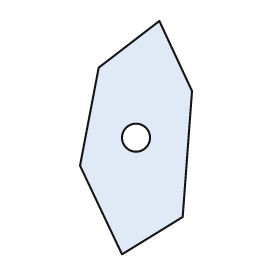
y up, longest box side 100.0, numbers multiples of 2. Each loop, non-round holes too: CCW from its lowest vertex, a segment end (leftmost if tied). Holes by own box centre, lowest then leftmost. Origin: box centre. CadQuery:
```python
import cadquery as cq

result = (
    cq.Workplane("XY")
    .moveTo(-6.0, -50.0)
    .lineTo(20.0, -34.0)
    .lineTo(24.0, 20.0)
    .lineTo(10.0, 50.0)
    .lineTo(-16.0, 30.0)
    .lineTo(-24.0, -12.0)
    .close()
    .moveTo(0.0, 0.0)
    .circle(6.0)
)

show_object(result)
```